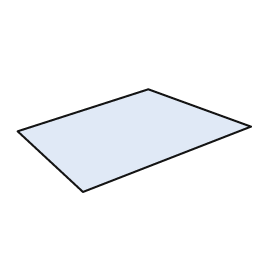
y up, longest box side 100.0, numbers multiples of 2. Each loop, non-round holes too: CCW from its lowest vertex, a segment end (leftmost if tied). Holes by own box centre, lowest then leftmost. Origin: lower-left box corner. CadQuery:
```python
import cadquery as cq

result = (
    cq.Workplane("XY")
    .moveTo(28.0, 0.0)
    .lineTo(100.0, 28.0)
    .lineTo(56.0, 44.0)
    .lineTo(0.0, 26.0)
    .close()
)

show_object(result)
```